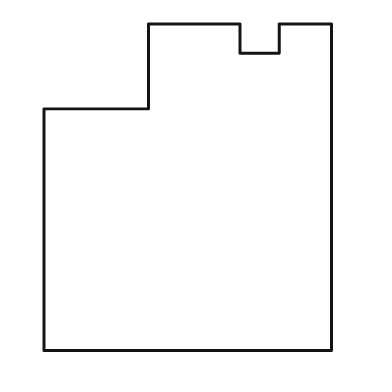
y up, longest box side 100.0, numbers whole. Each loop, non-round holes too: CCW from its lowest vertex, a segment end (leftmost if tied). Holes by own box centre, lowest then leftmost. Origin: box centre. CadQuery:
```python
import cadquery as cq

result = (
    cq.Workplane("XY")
    .moveTo(-44.0, -50.0)
    .lineTo(44.0, -50.0)
    .lineTo(44.0, 50.0)
    .lineTo(28.0, 50.0)
    .lineTo(28.0, 41.0)
    .lineTo(16.0, 41.0)
    .lineTo(16.0, 50.0)
    .lineTo(-12.0, 50.0)
    .lineTo(-12.0, 24.0)
    .lineTo(-44.0, 24.0)
    .close()
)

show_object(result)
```